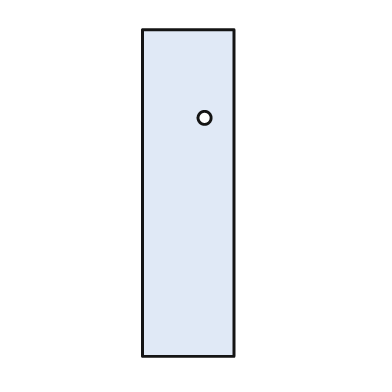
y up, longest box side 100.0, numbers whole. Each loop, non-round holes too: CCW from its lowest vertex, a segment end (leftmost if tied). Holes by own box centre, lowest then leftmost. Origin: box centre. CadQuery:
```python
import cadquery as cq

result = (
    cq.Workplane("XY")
    .moveTo(-14.0, -50.0)
    .lineTo(14.0, -50.0)
    .lineTo(14.0, 50.0)
    .lineTo(-14.0, 50.0)
    .close()
    .moveTo(5.0, 23.0)
    .circle(2.0)
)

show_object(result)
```